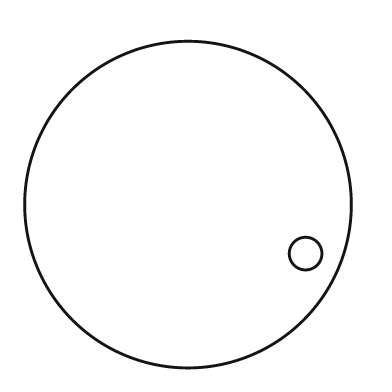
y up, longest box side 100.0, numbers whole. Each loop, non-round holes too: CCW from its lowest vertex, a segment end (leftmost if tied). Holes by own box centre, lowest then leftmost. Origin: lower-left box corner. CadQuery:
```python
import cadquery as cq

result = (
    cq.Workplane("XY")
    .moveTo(50.0, 50.0)
    .circle(50.0)
    .moveTo(86.0, 35.0)
    .circle(5.0)
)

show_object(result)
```